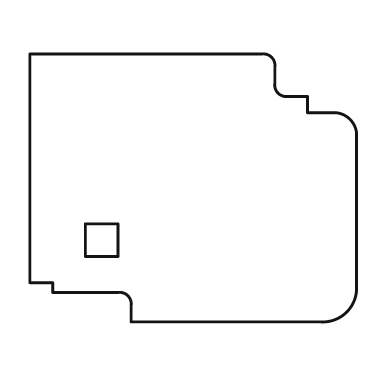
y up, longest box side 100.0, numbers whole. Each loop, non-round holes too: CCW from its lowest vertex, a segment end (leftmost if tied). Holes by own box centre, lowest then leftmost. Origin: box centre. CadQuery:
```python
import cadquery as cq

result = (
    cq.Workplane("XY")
    .moveTo(-19.0, -41.0)
    .lineTo(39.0, -41.0)
    .threePointArc((47.0, -38.0), (50.0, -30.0))
    .lineTo(50.0, 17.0)
    .threePointArc((48.0, 21.0), (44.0, 23.0))
    .lineTo(35.0, 23.0)
    .lineTo(35.0, 28.0)
    .lineTo(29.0, 28.0)
    .threePointArc((26.0, 29.0), (25.0, 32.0))
    .lineTo(25.0, 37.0)
    .threePointArc((24.0, 40.0), (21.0, 41.0))
    .lineTo(-50.0, 41.0)
    .lineTo(-50.0, -29.0)
    .lineTo(-43.0, -29.0)
    .lineTo(-43.0, -32.0)
    .lineTo(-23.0, -32.0)
    .threePointArc((-20.0, -33.0), (-19.0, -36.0))
    .close()
    .moveTo(-33.0, -21.0)
    .lineTo(-23.0, -21.0)
    .lineTo(-23.0, -11.0)
    .lineTo(-33.0, -11.0)
    .close()
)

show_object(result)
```